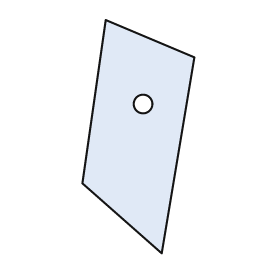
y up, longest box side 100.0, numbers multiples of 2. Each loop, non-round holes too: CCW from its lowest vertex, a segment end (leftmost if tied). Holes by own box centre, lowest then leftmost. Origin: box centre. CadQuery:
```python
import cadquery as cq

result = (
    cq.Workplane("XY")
    .moveTo(10.0, -50.0)
    .lineTo(24.0, 34.0)
    .lineTo(-14.0, 50.0)
    .lineTo(-24.0, -20.0)
    .close()
    .moveTo(2.0, 14.0)
    .circle(4.0)
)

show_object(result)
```